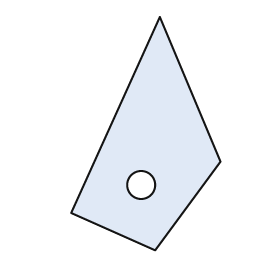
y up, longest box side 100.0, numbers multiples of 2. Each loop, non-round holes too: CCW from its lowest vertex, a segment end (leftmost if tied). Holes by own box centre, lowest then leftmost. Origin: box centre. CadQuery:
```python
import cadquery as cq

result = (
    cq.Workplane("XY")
    .moveTo(4.0, -50.0)
    .lineTo(32.0, -12.0)
    .lineTo(6.0, 50.0)
    .lineTo(-32.0, -34.0)
    .close()
    .moveTo(-2.0, -22.0)
    .circle(6.0)
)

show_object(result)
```